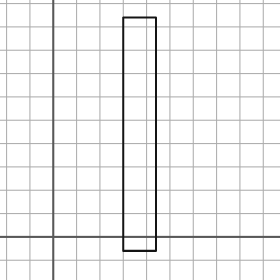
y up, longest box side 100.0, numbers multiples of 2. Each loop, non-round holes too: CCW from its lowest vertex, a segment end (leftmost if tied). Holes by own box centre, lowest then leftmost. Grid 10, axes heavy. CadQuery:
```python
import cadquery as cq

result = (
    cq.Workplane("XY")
    .moveTo(30.0, -6.0)
    .lineTo(44.0, -6.0)
    .lineTo(44.0, 94.0)
    .lineTo(30.0, 94.0)
    .close()
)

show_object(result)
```